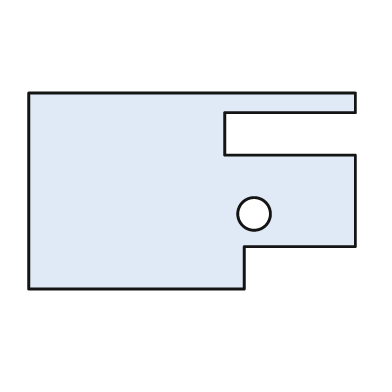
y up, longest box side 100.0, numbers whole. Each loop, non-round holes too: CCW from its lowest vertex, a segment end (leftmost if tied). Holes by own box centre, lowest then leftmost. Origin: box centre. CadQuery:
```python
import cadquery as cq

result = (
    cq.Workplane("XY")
    .moveTo(-50.0, -30.0)
    .lineTo(16.0, -30.0)
    .lineTo(16.0, -17.0)
    .lineTo(50.0, -17.0)
    .lineTo(50.0, 11.0)
    .lineTo(10.0, 11.0)
    .lineTo(10.0, 24.0)
    .lineTo(50.0, 24.0)
    .lineTo(50.0, 30.0)
    .lineTo(-50.0, 30.0)
    .close()
    .moveTo(19.0, -7.0)
    .circle(5.0)
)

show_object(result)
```